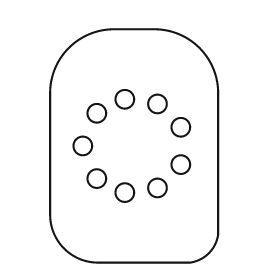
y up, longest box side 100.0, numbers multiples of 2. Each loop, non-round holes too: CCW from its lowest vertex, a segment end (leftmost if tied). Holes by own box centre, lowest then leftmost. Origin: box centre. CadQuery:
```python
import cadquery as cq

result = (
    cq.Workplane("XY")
    .moveTo(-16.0, -50.0)
    .lineTo(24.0, -50.0)
    .threePointArc((32.0, -46.0), (36.0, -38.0))
    .lineTo(36.0, 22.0)
    .threePointArc((28.0, 42.0), (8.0, 50.0))
    .lineTo(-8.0, 50.0)
    .threePointArc((-28.0, 42.0), (-36.0, 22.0))
    .lineTo(-36.0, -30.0)
    .threePointArc((-30.0, -44.0), (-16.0, -50.0))
    .close()
    .moveTo(-4.0, -20.0)
    .circle(4.0)
    .moveTo(10.0, -18.0)
    .circle(4.0)
    .moveTo(-16.0, -14.0)
    .circle(4.0)
    .moveTo(20.0, -8.0)
    .circle(4.0)
    .moveTo(-22.0, 0.0)
    .circle(4.0)
    .moveTo(20.0, 8.0)
    .circle(4.0)
    .moveTo(-16.0, 14.0)
    .circle(4.0)
    .moveTo(10.0, 18.0)
    .circle(4.0)
    .moveTo(-4.0, 20.0)
    .circle(4.0)
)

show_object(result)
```